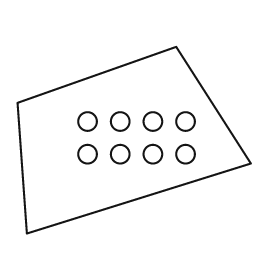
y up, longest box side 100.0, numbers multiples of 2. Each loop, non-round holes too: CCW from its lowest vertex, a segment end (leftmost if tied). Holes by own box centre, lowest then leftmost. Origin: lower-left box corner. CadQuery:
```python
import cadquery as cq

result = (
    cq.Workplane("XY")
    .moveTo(4.0, 0.0)
    .lineTo(100.0, 30.0)
    .lineTo(68.0, 80.0)
    .lineTo(0.0, 56.0)
    .close()
    .moveTo(30.0, 34.0)
    .circle(4.0)
    .moveTo(44.0, 34.0)
    .circle(4.0)
    .moveTo(58.0, 34.0)
    .circle(4.0)
    .moveTo(72.0, 34.0)
    .circle(4.0)
    .moveTo(30.0, 48.0)
    .circle(4.0)
    .moveTo(44.0, 48.0)
    .circle(4.0)
    .moveTo(58.0, 48.0)
    .circle(4.0)
    .moveTo(72.0, 48.0)
    .circle(4.0)
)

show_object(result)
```